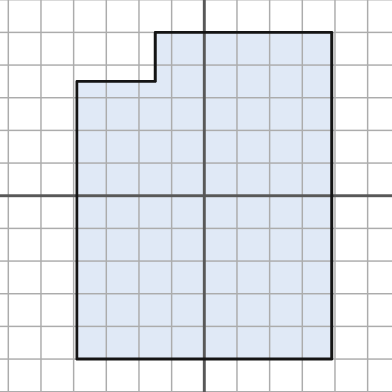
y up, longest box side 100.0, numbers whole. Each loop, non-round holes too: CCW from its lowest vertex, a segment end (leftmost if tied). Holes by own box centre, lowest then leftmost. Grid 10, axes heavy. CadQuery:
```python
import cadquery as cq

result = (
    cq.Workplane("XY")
    .moveTo(-39.0, -50.0)
    .lineTo(39.0, -50.0)
    .lineTo(39.0, 50.0)
    .lineTo(-15.0, 50.0)
    .lineTo(-15.0, 35.0)
    .lineTo(-39.0, 35.0)
    .close()
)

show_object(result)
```